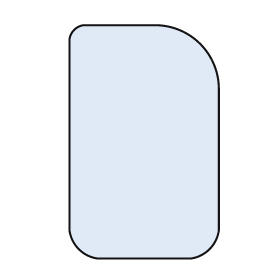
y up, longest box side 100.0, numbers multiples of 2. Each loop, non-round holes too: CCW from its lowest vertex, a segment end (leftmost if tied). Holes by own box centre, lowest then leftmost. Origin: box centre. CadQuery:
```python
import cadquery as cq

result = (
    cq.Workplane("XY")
    .moveTo(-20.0, -50.0)
    .lineTo(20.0, -50.0)
    .threePointArc((28.0, -46.0), (32.0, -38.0))
    .lineTo(32.0, 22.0)
    .threePointArc((24.0, 42.0), (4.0, 50.0))
    .lineTo(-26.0, 50.0)
    .threePointArc((-30.0, 48.0), (-32.0, 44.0))
    .lineTo(-32.0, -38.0)
    .threePointArc((-28.0, -46.0), (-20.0, -50.0))
    .close()
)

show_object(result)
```